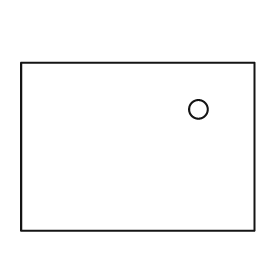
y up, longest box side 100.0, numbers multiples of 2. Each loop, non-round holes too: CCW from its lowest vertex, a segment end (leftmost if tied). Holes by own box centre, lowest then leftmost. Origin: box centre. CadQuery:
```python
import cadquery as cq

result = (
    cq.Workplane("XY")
    .moveTo(-50.0, -36.0)
    .lineTo(50.0, -36.0)
    .lineTo(50.0, 36.0)
    .lineTo(-50.0, 36.0)
    .close()
    .moveTo(26.0, 16.0)
    .circle(4.0)
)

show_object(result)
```